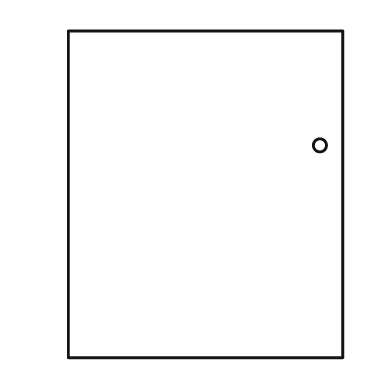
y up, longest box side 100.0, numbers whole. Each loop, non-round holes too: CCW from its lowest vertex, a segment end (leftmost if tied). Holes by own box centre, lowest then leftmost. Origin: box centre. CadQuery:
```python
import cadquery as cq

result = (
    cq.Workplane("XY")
    .moveTo(-42.0, -50.0)
    .lineTo(42.0, -50.0)
    .lineTo(42.0, 50.0)
    .lineTo(-42.0, 50.0)
    .close()
    .moveTo(35.0, 15.0)
    .circle(2.0)
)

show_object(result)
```